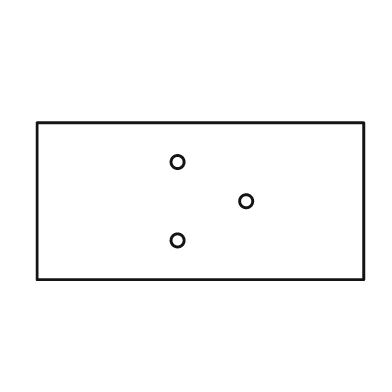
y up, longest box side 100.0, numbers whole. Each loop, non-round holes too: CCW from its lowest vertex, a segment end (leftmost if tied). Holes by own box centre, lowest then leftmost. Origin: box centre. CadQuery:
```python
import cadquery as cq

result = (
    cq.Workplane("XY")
    .moveTo(-50.0, -24.0)
    .lineTo(50.0, -24.0)
    .lineTo(50.0, 24.0)
    .lineTo(-50.0, 24.0)
    .close()
    .moveTo(-7.0, -12.0)
    .circle(2.0)
    .moveTo(14.0, 0.0)
    .circle(2.0)
    .moveTo(-7.0, 12.0)
    .circle(2.0)
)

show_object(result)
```